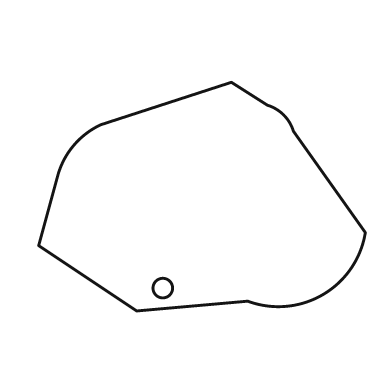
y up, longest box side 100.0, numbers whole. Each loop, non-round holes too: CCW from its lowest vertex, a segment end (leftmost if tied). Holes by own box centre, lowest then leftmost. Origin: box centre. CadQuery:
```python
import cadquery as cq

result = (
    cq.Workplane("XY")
    .moveTo(-20.0, -35.0)
    .lineTo(14.0, -32.0)
    .threePointArc((37.0, -30.0), (50.0, -11.0))
    .lineTo(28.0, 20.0)
    .threePointArc((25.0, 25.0), (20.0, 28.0))
    .lineTo(9.0, 35.0)
    .lineTo(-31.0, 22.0)
    .threePointArc((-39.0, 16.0), (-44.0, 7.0))
    .lineTo(-50.0, -15.0)
    .close()
    .moveTo(-12.0, -28.0)
    .circle(3.0)
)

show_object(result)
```